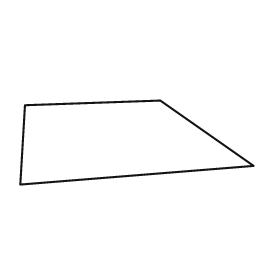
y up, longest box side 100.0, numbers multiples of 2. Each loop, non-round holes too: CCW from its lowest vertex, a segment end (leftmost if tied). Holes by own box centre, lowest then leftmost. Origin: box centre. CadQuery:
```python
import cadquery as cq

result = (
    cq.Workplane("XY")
    .moveTo(-50.0, -18.0)
    .lineTo(50.0, -10.0)
    .lineTo(10.0, 18.0)
    .lineTo(-48.0, 16.0)
    .close()
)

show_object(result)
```